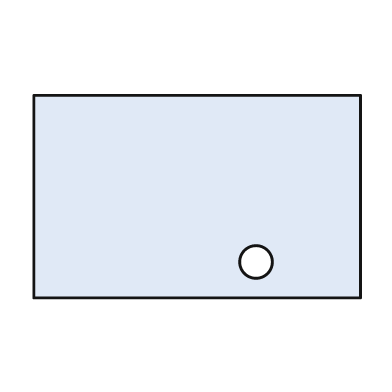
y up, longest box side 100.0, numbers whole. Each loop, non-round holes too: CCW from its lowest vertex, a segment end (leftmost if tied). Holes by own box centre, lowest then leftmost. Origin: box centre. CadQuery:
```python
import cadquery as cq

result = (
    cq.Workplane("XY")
    .moveTo(-50.0, -31.0)
    .lineTo(50.0, -31.0)
    .lineTo(50.0, 31.0)
    .lineTo(-50.0, 31.0)
    .close()
    .moveTo(18.0, -20.0)
    .circle(5.0)
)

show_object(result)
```